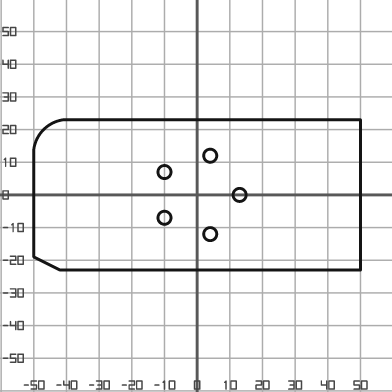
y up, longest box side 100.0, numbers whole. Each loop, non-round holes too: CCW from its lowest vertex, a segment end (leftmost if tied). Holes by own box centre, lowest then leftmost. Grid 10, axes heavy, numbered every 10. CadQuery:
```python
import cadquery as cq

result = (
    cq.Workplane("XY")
    .moveTo(-42.0, -23.0)
    .lineTo(50.0, -23.0)
    .lineTo(50.0, 23.0)
    .lineTo(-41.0, 23.0)
    .threePointArc((-47.0, 20.0), (-50.0, 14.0))
    .lineTo(-50.0, -19.0)
    .close()
    .moveTo(4.0, -12.0)
    .circle(2.0)
    .moveTo(-10.0, -7.0)
    .circle(2.0)
    .moveTo(13.0, 0.0)
    .circle(2.0)
    .moveTo(-10.0, 7.0)
    .circle(2.0)
    .moveTo(4.0, 12.0)
    .circle(2.0)
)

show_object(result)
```